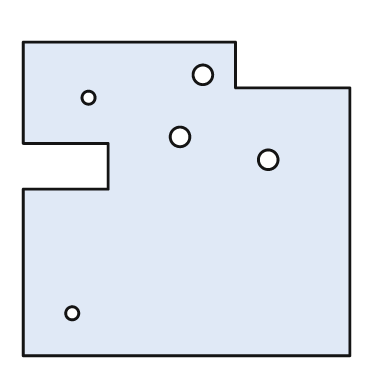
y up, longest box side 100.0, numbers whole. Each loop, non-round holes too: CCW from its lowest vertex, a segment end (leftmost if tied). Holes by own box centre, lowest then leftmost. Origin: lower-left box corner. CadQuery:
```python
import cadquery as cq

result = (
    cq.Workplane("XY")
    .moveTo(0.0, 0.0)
    .lineTo(100.0, 0.0)
    .lineTo(100.0, 82.0)
    .lineTo(65.0, 82.0)
    .lineTo(65.0, 96.0)
    .lineTo(0.0, 96.0)
    .lineTo(0.0, 65.0)
    .lineTo(26.0, 65.0)
    .lineTo(26.0, 51.0)
    .lineTo(0.0, 51.0)
    .close()
    .moveTo(15.0, 13.0)
    .circle(2.0)
    .moveTo(75.0, 60.0)
    .circle(3.0)
    .moveTo(48.0, 67.0)
    .circle(3.0)
    .moveTo(20.0, 79.0)
    .circle(2.0)
    .moveTo(55.0, 86.0)
    .circle(3.0)
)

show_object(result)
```